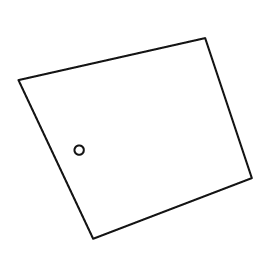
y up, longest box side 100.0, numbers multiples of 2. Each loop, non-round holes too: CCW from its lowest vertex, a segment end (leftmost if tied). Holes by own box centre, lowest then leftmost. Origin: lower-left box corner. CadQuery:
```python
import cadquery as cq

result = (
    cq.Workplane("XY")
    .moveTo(32.0, 0.0)
    .lineTo(100.0, 26.0)
    .lineTo(80.0, 86.0)
    .lineTo(0.0, 68.0)
    .close()
    .moveTo(26.0, 38.0)
    .circle(2.0)
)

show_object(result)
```